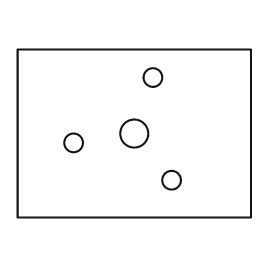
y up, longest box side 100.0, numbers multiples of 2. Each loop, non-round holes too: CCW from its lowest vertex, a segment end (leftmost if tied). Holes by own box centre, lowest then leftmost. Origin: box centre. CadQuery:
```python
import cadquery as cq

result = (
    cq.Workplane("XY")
    .moveTo(-50.0, -36.0)
    .lineTo(50.0, -36.0)
    .lineTo(50.0, 36.0)
    .lineTo(-50.0, 36.0)
    .close()
    .moveTo(16.0, -20.0)
    .circle(4.0)
    .moveTo(-26.0, -4.0)
    .circle(4.0)
    .moveTo(0.0, 0.0)
    .circle(6.0)
    .moveTo(8.0, 24.0)
    .circle(4.0)
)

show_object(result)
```